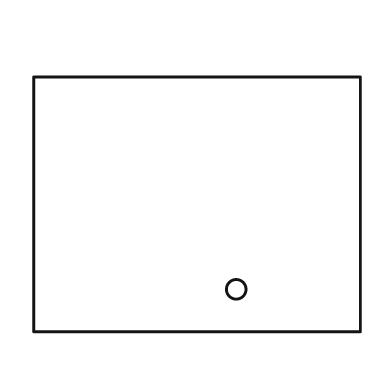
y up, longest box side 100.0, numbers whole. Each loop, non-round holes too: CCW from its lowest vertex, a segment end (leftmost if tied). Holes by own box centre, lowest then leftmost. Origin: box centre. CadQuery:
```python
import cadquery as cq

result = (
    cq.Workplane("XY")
    .moveTo(-50.0, -39.0)
    .lineTo(50.0, -39.0)
    .lineTo(50.0, 39.0)
    .lineTo(-50.0, 39.0)
    .close()
    .moveTo(12.0, -26.0)
    .circle(3.0)
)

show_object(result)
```